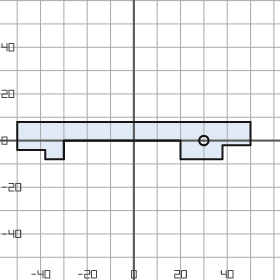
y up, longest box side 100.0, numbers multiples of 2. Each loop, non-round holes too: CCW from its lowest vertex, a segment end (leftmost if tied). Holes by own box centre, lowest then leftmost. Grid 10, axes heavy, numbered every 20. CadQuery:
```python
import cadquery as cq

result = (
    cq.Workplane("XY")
    .moveTo(-38.0, -8.0)
    .lineTo(-30.0, -8.0)
    .lineTo(-30.0, 0.0)
    .lineTo(20.0, 0.0)
    .lineTo(20.0, -8.0)
    .lineTo(38.0, -8.0)
    .lineTo(38.0, -2.0)
    .lineTo(50.0, -2.0)
    .lineTo(50.0, 8.0)
    .lineTo(-50.0, 8.0)
    .lineTo(-50.0, -4.0)
    .lineTo(-38.0, -4.0)
    .close()
    .moveTo(30.0, 0.0)
    .circle(2.0)
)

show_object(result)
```